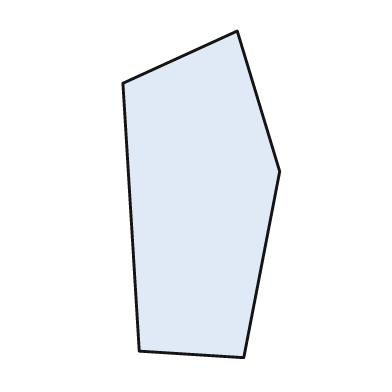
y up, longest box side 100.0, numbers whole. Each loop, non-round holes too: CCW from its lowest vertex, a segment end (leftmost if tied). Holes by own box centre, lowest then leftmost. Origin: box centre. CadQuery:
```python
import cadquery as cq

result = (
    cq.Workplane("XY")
    .moveTo(13.0, -50.0)
    .lineTo(24.0, 7.0)
    .lineTo(11.0, 50.0)
    .lineTo(-24.0, 34.0)
    .lineTo(-19.0, -48.0)
    .close()
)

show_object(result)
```